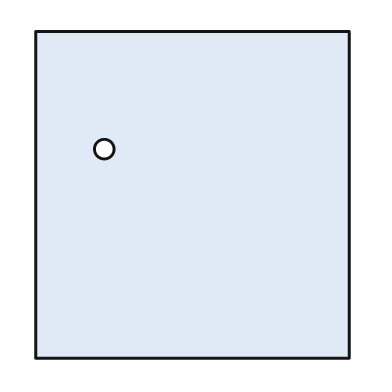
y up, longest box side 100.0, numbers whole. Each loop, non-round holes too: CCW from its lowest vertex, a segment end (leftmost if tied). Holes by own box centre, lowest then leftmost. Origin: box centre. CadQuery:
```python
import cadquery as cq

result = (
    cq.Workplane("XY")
    .moveTo(-48.0, -50.0)
    .lineTo(48.0, -50.0)
    .lineTo(48.0, 50.0)
    .lineTo(-48.0, 50.0)
    .close()
    .moveTo(-27.0, 14.0)
    .circle(3.0)
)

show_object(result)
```